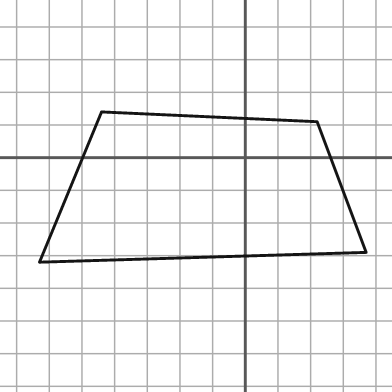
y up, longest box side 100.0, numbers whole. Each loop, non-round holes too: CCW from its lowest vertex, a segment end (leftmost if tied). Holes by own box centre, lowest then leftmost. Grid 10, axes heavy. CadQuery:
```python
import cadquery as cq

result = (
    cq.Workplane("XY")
    .moveTo(-63.0, -32.0)
    .lineTo(37.0, -29.0)
    .lineTo(22.0, 11.0)
    .lineTo(-44.0, 14.0)
    .close()
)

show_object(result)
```